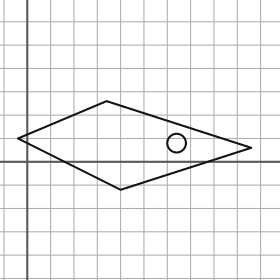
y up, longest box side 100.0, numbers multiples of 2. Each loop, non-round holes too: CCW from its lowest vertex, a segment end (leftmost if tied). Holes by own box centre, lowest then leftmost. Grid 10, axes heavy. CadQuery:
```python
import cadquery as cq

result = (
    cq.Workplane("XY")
    .moveTo(40.0, -12.0)
    .lineTo(96.0, 6.0)
    .lineTo(34.0, 26.0)
    .lineTo(-4.0, 10.0)
    .close()
    .moveTo(64.0, 8.0)
    .circle(4.0)
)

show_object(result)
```